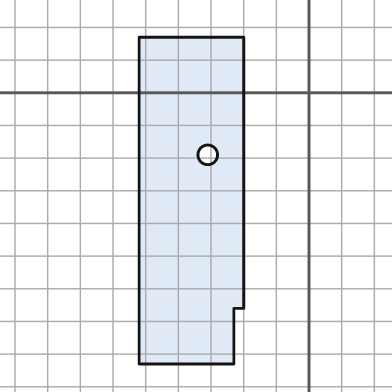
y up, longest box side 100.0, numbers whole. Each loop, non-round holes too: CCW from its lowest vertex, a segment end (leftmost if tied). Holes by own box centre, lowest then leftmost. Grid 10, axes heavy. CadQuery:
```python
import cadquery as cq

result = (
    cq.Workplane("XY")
    .moveTo(-52.0, -83.0)
    .lineTo(-23.0, -83.0)
    .lineTo(-23.0, -66.0)
    .lineTo(-20.0, -66.0)
    .lineTo(-20.0, 17.0)
    .lineTo(-52.0, 17.0)
    .close()
    .moveTo(-31.0, -19.0)
    .circle(3.0)
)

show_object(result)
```